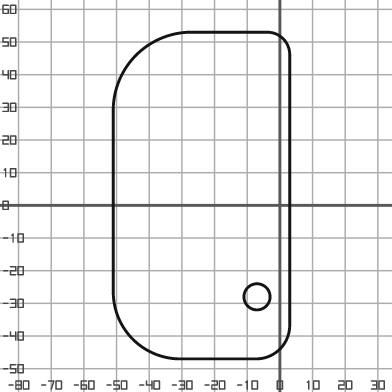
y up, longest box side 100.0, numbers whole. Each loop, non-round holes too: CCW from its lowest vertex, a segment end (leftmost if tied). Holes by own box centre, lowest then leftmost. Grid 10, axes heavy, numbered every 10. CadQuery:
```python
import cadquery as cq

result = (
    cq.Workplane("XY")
    .moveTo(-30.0, -47.0)
    .lineTo(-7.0, -47.0)
    .threePointArc((0.0, -44.0), (3.0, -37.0))
    .lineTo(3.0, 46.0)
    .threePointArc((1.0, 51.0), (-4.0, 53.0))
    .lineTo(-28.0, 53.0)
    .threePointArc((-44.0, 46.0), (-51.0, 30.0))
    .lineTo(-51.0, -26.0)
    .threePointArc((-45.0, -41.0), (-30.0, -47.0))
    .close()
    .moveTo(-7.0, -28.0)
    .circle(4.0)
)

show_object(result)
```